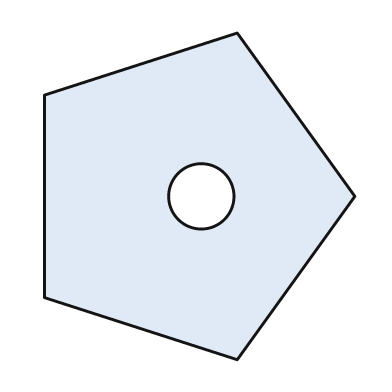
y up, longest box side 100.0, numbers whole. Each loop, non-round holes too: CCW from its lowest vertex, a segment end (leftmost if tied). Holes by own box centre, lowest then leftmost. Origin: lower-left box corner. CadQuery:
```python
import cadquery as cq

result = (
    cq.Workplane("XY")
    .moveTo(59.0, 0.0)
    .lineTo(95.0, 50.0)
    .lineTo(59.0, 100.0)
    .lineTo(0.0, 81.0)
    .lineTo(0.0, 19.0)
    .close()
    .moveTo(48.0, 50.0)
    .circle(10.0)
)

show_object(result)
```